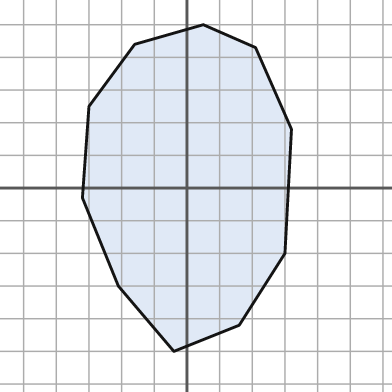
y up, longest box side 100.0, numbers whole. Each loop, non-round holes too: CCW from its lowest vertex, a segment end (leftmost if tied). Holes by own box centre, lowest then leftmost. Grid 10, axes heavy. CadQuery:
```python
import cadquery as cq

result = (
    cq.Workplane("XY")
    .moveTo(-4.0, -50.0)
    .lineTo(16.0, -42.0)
    .lineTo(30.0, -20.0)
    .lineTo(32.0, 18.0)
    .lineTo(21.0, 43.0)
    .lineTo(5.0, 50.0)
    .lineTo(-16.0, 44.0)
    .lineTo(-30.0, 25.0)
    .lineTo(-32.0, -3.0)
    .lineTo(-21.0, -30.0)
    .close()
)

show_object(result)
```